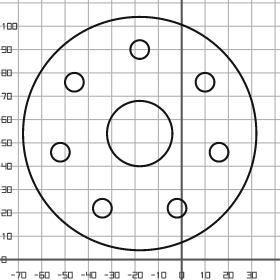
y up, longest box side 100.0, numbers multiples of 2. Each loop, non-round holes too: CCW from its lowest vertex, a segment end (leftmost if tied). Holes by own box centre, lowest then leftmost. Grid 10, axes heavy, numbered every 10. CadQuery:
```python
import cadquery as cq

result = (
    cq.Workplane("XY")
    .moveTo(-18.0, 54.0)
    .circle(50.0)
    .moveTo(-34.0, 22.0)
    .circle(4.0)
    .moveTo(-2.0, 22.0)
    .circle(4.0)
    .moveTo(-52.0, 46.0)
    .circle(4.0)
    .moveTo(16.0, 46.0)
    .circle(4.0)
    .moveTo(-18.0, 54.0)
    .circle(14.0)
    .moveTo(-46.0, 76.0)
    .circle(4.0)
    .moveTo(10.0, 76.0)
    .circle(4.0)
    .moveTo(-18.0, 90.0)
    .circle(4.0)
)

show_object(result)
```